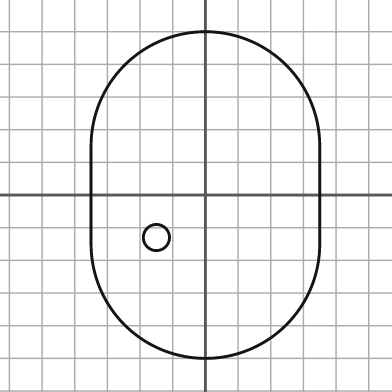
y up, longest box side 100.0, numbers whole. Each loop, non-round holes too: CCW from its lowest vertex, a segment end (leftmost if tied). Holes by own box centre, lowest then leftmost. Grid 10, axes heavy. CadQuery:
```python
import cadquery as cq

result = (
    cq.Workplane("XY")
    .moveTo(-35.0, -15.0)
    .threePointArc((0.0, -50.0), (35.0, -15.0))
    .lineTo(35.0, 15.0)
    .threePointArc((0.0, 50.0), (-35.0, 15.0))
    .close()
    .moveTo(-15.0, -13.0)
    .circle(4.0)
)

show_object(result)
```